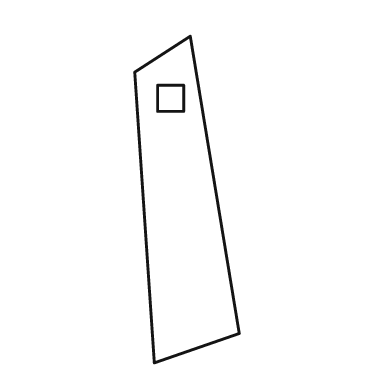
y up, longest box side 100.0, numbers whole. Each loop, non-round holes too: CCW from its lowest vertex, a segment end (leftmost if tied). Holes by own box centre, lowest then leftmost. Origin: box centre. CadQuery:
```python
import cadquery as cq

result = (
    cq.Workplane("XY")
    .moveTo(-10.0, -50.0)
    .lineTo(16.0, -41.0)
    .lineTo(1.0, 50.0)
    .lineTo(-16.0, 39.0)
    .close()
    .moveTo(-9.0, 27.0)
    .lineTo(-1.0, 27.0)
    .lineTo(-1.0, 35.0)
    .lineTo(-9.0, 35.0)
    .close()
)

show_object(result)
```